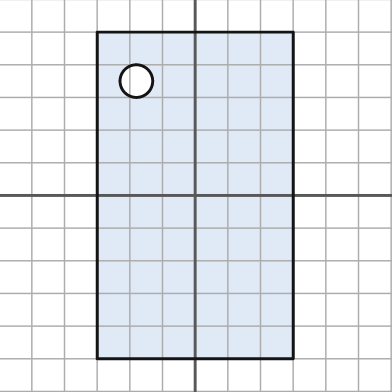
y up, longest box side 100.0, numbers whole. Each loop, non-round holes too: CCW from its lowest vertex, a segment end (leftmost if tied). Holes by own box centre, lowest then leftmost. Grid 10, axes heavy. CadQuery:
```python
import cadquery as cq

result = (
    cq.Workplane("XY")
    .moveTo(-30.0, -50.0)
    .lineTo(30.0, -50.0)
    .lineTo(30.0, 50.0)
    .lineTo(-30.0, 50.0)
    .close()
    .moveTo(-18.0, 35.0)
    .circle(5.0)
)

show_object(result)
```